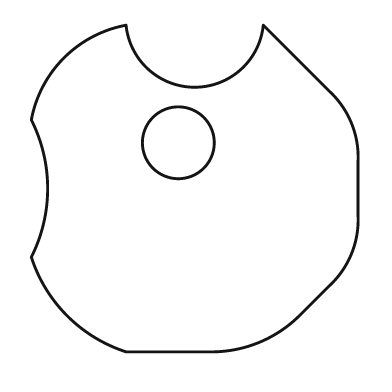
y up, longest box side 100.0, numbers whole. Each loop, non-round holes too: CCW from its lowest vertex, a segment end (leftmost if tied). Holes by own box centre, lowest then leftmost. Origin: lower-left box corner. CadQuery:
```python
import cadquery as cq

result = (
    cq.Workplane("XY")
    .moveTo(29.0, 0.0)
    .lineTo(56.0, 0.0)
    .threePointArc((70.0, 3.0), (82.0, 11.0))
    .lineTo(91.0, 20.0)
    .threePointArc((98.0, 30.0), (100.0, 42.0))
    .lineTo(100.0, 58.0)
    .threePointArc((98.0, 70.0), (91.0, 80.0))
    .lineTo(71.0, 100.0)
    .threePointArc((50.0, 81.0), (29.0, 100.0))
    .threePointArc((10.0, 90.0), (0.0, 71.0))
    .threePointArc((5.0, 50.0), (0.0, 29.0))
    .threePointArc((11.0, 11.0), (29.0, 0.0))
    .close()
    .moveTo(45.0, 64.0)
    .circle(11.0)
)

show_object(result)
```